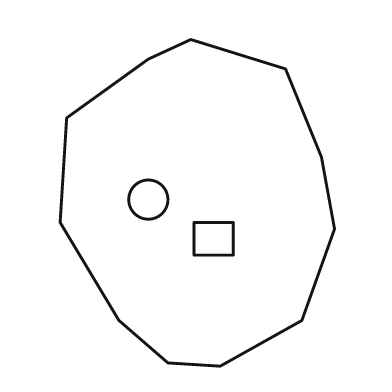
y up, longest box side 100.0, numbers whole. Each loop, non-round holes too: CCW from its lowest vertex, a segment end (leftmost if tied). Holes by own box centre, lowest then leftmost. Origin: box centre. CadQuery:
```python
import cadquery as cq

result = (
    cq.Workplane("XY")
    .moveTo(7.0, -50.0)
    .lineTo(32.0, -36.0)
    .lineTo(42.0, -8.0)
    .lineTo(38.0, 14.0)
    .lineTo(27.0, 41.0)
    .lineTo(-2.0, 50.0)
    .lineTo(-15.0, 44.0)
    .lineTo(-40.0, 26.0)
    .lineTo(-42.0, -6.0)
    .lineTo(-24.0, -36.0)
    .lineTo(-9.0, -49.0)
    .close()
    .moveTo(-1.0, -16.0)
    .lineTo(11.0, -16.0)
    .lineTo(11.0, -6.0)
    .lineTo(-1.0, -6.0)
    .close()
    .moveTo(-15.0, 1.0)
    .circle(6.0)
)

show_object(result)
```